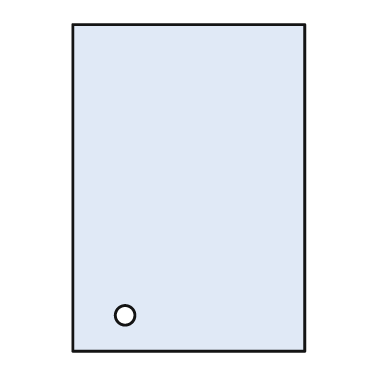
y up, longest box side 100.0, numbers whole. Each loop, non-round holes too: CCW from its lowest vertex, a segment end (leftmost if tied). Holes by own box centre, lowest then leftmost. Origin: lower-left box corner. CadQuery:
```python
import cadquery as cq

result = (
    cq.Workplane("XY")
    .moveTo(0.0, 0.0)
    .lineTo(71.0, 0.0)
    .lineTo(71.0, 100.0)
    .lineTo(0.0, 100.0)
    .close()
    .moveTo(16.0, 11.0)
    .circle(3.0)
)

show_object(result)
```